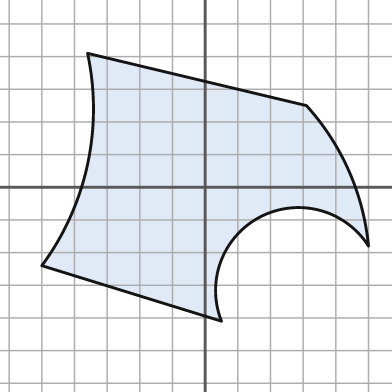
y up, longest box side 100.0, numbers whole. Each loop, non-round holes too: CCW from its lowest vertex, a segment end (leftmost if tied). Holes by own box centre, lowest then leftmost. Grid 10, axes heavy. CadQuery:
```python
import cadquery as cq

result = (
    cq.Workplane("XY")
    .moveTo(5.0, -41.0)
    .threePointArc((17.0, -9.0), (50.0, -18.0))
    .threePointArc((44.0, 5.0), (31.0, 25.0))
    .lineTo(-36.0, 41.0)
    .threePointArc((-36.0, 7.0), (-50.0, -24.0))
    .close()
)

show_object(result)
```